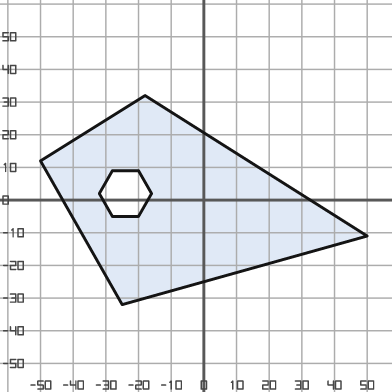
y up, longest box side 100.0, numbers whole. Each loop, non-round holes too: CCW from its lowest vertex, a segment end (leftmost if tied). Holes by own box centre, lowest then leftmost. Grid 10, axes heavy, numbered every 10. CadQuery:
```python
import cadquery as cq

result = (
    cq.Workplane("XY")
    .moveTo(-25.0, -32.0)
    .lineTo(50.0, -11.0)
    .lineTo(-18.0, 32.0)
    .lineTo(-50.0, 12.0)
    .close()
    .moveTo(-28.0, -5.0)
    .lineTo(-20.0, -5.0)
    .lineTo(-16.0, 2.0)
    .lineTo(-20.0, 9.0)
    .lineTo(-28.0, 9.0)
    .lineTo(-32.0, 2.0)
    .close()
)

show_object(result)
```